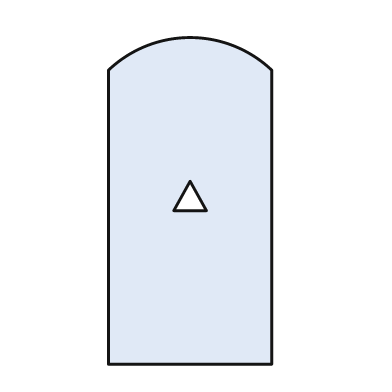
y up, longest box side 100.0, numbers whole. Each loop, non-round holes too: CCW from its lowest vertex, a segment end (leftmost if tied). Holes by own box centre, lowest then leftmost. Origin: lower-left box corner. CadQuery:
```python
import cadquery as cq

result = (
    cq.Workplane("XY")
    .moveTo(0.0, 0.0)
    .lineTo(50.0, 0.0)
    .lineTo(50.0, 90.0)
    .threePointArc((25.0, 100.0), (0.0, 90.0))
    .close()
    .moveTo(20.0, 47.0)
    .lineTo(30.0, 47.0)
    .lineTo(25.0, 56.0)
    .close()
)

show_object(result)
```